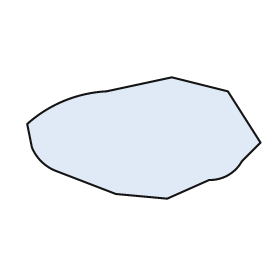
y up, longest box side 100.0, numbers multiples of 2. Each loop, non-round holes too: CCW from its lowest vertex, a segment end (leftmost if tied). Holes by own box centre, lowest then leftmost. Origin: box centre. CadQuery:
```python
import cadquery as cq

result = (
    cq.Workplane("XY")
    .moveTo(10.0, -26.0)
    .lineTo(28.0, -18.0)
    .threePointArc((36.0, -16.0), (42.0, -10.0))
    .lineTo(50.0, -2.0)
    .lineTo(36.0, 20.0)
    .lineTo(12.0, 26.0)
    .lineTo(-16.0, 20.0)
    .threePointArc((-34.0, 16.0), (-50.0, 6.0))
    .lineTo(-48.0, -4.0)
    .threePointArc((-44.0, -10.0), (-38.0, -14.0))
    .lineTo(-12.0, -24.0)
    .close()
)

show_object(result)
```